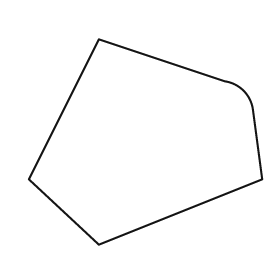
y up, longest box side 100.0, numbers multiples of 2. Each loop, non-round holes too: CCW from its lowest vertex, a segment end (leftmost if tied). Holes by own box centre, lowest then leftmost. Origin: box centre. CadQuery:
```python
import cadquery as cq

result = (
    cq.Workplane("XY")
    .moveTo(-20.0, -44.0)
    .lineTo(50.0, -16.0)
    .lineTo(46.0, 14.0)
    .threePointArc((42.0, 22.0), (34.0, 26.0))
    .lineTo(-20.0, 44.0)
    .lineTo(-50.0, -16.0)
    .close()
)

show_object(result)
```